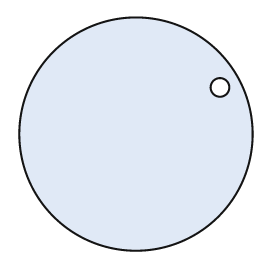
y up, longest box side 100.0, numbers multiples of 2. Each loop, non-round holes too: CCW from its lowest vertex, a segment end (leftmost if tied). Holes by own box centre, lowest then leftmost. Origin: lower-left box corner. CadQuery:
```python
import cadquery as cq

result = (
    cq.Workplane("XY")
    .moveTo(50.0, 50.0)
    .circle(50.0)
    .moveTo(86.0, 70.0)
    .circle(4.0)
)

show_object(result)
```